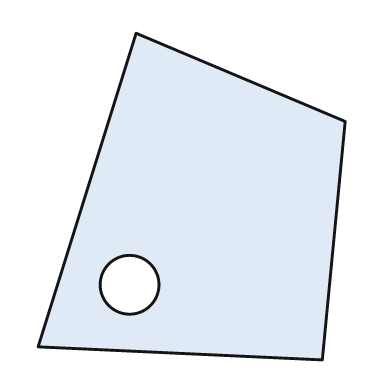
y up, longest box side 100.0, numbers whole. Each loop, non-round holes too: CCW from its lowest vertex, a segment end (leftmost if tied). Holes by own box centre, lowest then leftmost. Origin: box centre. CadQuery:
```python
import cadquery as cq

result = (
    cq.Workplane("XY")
    .moveTo(40.0, -50.0)
    .lineTo(47.0, 23.0)
    .lineTo(-17.0, 50.0)
    .lineTo(-47.0, -46.0)
    .close()
    .moveTo(-19.0, -27.0)
    .circle(9.0)
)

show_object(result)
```